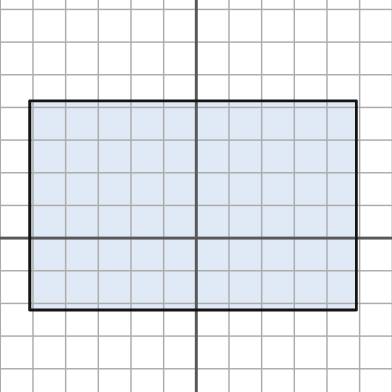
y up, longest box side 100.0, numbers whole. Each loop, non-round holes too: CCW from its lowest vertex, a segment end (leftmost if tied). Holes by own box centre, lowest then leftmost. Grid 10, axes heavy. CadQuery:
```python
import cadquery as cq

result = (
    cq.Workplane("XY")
    .moveTo(-51.0, -22.0)
    .lineTo(49.0, -22.0)
    .lineTo(49.0, 42.0)
    .lineTo(-51.0, 42.0)
    .close()
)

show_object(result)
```